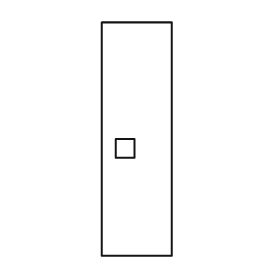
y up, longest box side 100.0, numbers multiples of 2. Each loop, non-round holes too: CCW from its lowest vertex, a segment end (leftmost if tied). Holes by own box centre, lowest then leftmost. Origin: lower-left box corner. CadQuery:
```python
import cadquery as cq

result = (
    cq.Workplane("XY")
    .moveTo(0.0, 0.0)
    .lineTo(30.0, 0.0)
    .lineTo(30.0, 100.0)
    .lineTo(0.0, 100.0)
    .close()
    .moveTo(6.0, 42.0)
    .lineTo(14.0, 42.0)
    .lineTo(14.0, 50.0)
    .lineTo(6.0, 50.0)
    .close()
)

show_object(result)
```